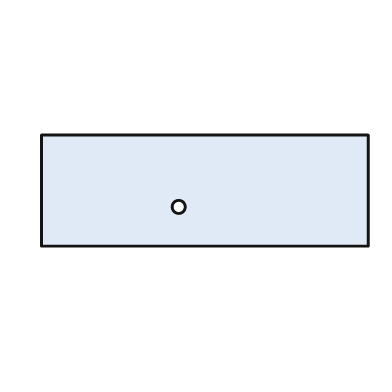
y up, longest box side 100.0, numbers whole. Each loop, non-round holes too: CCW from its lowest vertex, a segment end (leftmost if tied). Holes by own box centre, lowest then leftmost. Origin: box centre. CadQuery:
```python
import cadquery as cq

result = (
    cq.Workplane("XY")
    .moveTo(-50.0, -17.0)
    .lineTo(50.0, -17.0)
    .lineTo(50.0, 17.0)
    .lineTo(-50.0, 17.0)
    .close()
    .moveTo(-8.0, -5.0)
    .circle(2.0)
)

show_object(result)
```